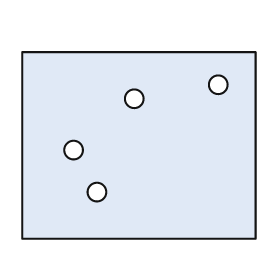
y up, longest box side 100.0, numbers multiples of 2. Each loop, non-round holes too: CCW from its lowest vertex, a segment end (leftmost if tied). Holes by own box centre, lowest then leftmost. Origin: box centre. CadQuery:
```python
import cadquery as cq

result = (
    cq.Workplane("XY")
    .moveTo(-50.0, -40.0)
    .lineTo(50.0, -40.0)
    .lineTo(50.0, 40.0)
    .lineTo(-50.0, 40.0)
    .close()
    .moveTo(-18.0, -20.0)
    .circle(4.0)
    .moveTo(-28.0, -2.0)
    .circle(4.0)
    .moveTo(-2.0, 20.0)
    .circle(4.0)
    .moveTo(34.0, 26.0)
    .circle(4.0)
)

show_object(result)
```